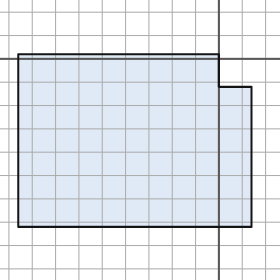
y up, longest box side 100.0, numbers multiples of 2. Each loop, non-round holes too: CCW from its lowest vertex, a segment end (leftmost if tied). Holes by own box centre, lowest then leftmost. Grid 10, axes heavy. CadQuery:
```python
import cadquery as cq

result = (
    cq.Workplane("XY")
    .moveTo(-86.0, -72.0)
    .lineTo(14.0, -72.0)
    .lineTo(14.0, -12.0)
    .lineTo(0.0, -12.0)
    .lineTo(0.0, 2.0)
    .lineTo(-86.0, 2.0)
    .close()
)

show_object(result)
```